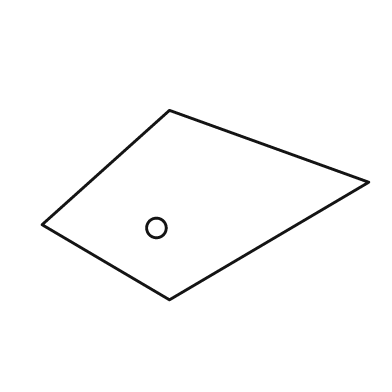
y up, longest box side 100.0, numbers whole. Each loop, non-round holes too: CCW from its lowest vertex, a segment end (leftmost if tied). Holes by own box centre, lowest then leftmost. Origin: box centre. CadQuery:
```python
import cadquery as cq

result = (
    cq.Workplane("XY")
    .moveTo(-11.0, -29.0)
    .lineTo(50.0, 7.0)
    .lineTo(-11.0, 29.0)
    .lineTo(-50.0, -6.0)
    .close()
    .moveTo(-15.0, -7.0)
    .circle(3.0)
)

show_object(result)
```